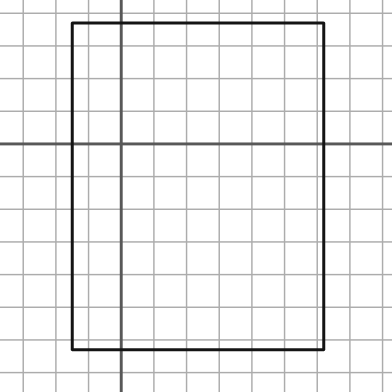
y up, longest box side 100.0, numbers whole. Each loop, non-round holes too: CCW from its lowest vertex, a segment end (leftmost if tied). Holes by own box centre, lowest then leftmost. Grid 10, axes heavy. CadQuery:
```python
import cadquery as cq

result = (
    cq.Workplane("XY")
    .moveTo(-15.0, -63.0)
    .lineTo(62.0, -63.0)
    .lineTo(62.0, 37.0)
    .lineTo(-15.0, 37.0)
    .close()
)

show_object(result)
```